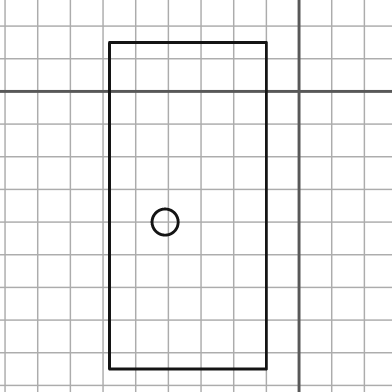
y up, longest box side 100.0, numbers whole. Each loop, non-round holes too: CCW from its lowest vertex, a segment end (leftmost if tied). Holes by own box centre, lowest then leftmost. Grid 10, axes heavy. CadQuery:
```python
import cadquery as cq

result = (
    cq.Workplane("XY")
    .moveTo(-58.0, -85.0)
    .lineTo(-10.0, -85.0)
    .lineTo(-10.0, 15.0)
    .lineTo(-58.0, 15.0)
    .close()
    .moveTo(-41.0, -40.0)
    .circle(4.0)
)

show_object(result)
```